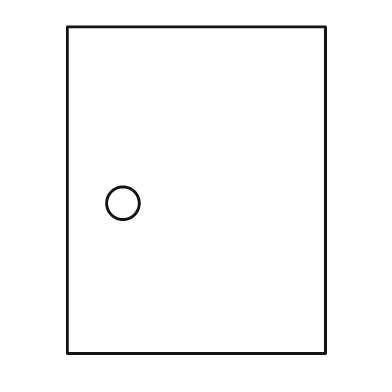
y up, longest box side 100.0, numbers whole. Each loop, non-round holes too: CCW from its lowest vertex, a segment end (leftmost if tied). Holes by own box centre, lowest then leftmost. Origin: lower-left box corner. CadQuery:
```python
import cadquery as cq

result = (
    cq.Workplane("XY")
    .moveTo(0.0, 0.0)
    .lineTo(79.0, 0.0)
    .lineTo(79.0, 100.0)
    .lineTo(0.0, 100.0)
    .close()
    .moveTo(17.0, 46.0)
    .circle(5.0)
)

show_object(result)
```